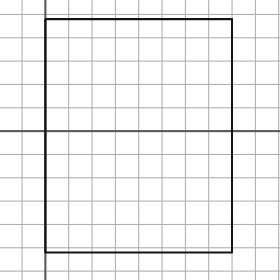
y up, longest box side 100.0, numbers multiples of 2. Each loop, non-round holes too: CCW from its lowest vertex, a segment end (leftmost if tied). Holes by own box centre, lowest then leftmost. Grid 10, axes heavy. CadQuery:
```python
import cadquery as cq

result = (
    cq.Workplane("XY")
    .moveTo(0.0, -52.0)
    .lineTo(80.0, -52.0)
    .lineTo(80.0, 48.0)
    .lineTo(0.0, 48.0)
    .close()
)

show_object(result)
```